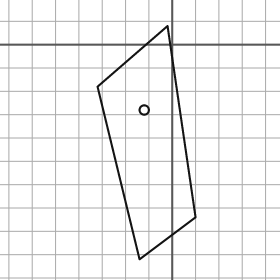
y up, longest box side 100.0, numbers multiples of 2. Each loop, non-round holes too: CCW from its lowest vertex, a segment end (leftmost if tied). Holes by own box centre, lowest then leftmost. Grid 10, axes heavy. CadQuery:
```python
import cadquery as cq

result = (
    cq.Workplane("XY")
    .moveTo(-14.0, -92.0)
    .lineTo(10.0, -74.0)
    .lineTo(-2.0, 8.0)
    .lineTo(-32.0, -18.0)
    .close()
    .moveTo(-12.0, -28.0)
    .circle(2.0)
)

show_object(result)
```